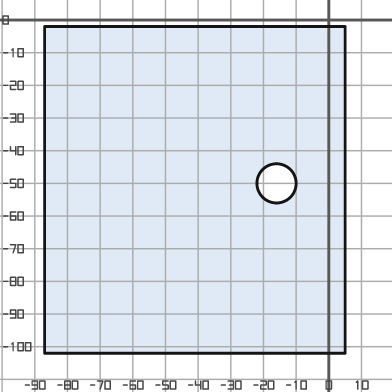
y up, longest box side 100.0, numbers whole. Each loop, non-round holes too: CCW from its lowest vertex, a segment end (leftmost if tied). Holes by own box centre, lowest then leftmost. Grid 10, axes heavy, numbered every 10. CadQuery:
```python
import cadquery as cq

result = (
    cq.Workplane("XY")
    .moveTo(-87.0, -102.0)
    .lineTo(5.0, -102.0)
    .lineTo(5.0, -2.0)
    .lineTo(-87.0, -2.0)
    .close()
    .moveTo(-16.0, -50.0)
    .circle(6.0)
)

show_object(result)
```